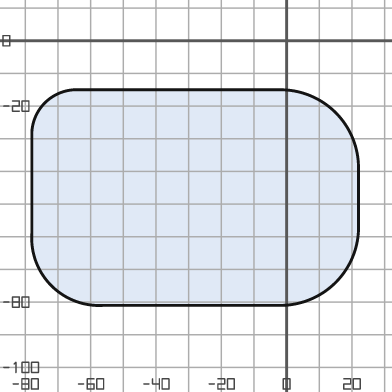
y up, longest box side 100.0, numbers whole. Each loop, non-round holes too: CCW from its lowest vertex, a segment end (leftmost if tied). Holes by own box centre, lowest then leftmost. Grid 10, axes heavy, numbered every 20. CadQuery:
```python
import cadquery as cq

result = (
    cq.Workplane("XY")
    .moveTo(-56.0, -81.0)
    .lineTo(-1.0, -81.0)
    .threePointArc((15.0, -74.0), (22.0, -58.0))
    .lineTo(22.0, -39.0)
    .threePointArc((15.0, -22.0), (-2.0, -15.0))
    .lineTo(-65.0, -15.0)
    .threePointArc((-74.0, -19.0), (-78.0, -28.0))
    .lineTo(-78.0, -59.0)
    .threePointArc((-72.0, -75.0), (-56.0, -81.0))
    .close()
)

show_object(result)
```